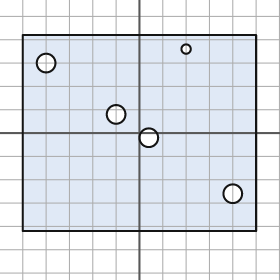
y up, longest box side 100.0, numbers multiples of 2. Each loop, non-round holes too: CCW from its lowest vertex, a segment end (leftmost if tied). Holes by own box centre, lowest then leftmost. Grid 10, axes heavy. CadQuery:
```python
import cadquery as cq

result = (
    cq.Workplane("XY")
    .moveTo(-50.0, -42.0)
    .lineTo(50.0, -42.0)
    .lineTo(50.0, 42.0)
    .lineTo(-50.0, 42.0)
    .close()
    .moveTo(40.0, -26.0)
    .circle(4.0)
    .moveTo(4.0, -2.0)
    .circle(4.0)
    .moveTo(-10.0, 8.0)
    .circle(4.0)
    .moveTo(-40.0, 30.0)
    .circle(4.0)
    .moveTo(20.0, 36.0)
    .circle(2.0)
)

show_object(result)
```